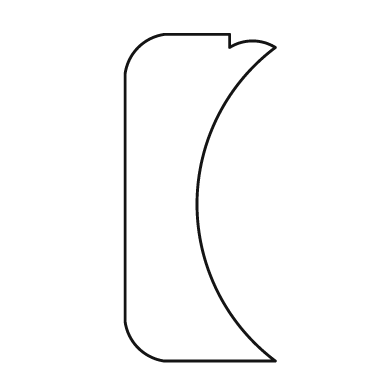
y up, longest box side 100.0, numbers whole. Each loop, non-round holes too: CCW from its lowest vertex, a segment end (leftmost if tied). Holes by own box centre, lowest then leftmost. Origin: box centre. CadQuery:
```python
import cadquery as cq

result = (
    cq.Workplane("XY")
    .moveTo(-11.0, -50.0)
    .lineTo(23.0, -50.0)
    .threePointArc((-1.0, -2.0), (23.0, 46.0))
    .threePointArc((16.0, 48.0), (9.0, 46.0))
    .lineTo(9.0, 50.0)
    .lineTo(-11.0, 50.0)
    .threePointArc((-19.0, 46.0), (-23.0, 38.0))
    .lineTo(-23.0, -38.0)
    .threePointArc((-19.0, -46.0), (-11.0, -50.0))
    .close()
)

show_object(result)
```